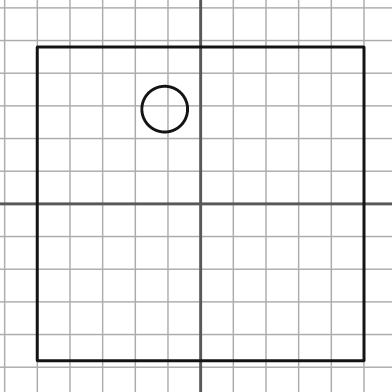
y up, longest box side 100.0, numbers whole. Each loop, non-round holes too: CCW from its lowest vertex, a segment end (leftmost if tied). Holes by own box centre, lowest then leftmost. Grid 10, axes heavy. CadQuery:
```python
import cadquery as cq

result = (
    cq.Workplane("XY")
    .moveTo(-50.0, -48.0)
    .lineTo(50.0, -48.0)
    .lineTo(50.0, 48.0)
    .lineTo(-50.0, 48.0)
    .close()
    .moveTo(-11.0, 29.0)
    .circle(7.0)
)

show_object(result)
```